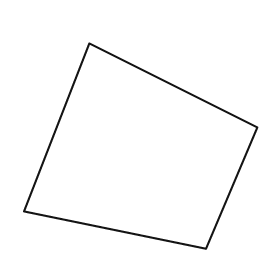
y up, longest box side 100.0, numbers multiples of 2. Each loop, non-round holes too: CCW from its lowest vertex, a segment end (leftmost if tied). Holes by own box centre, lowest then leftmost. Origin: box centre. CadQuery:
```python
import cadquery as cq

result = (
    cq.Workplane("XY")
    .moveTo(28.0, -44.0)
    .lineTo(50.0, 8.0)
    .lineTo(-22.0, 44.0)
    .lineTo(-50.0, -28.0)
    .close()
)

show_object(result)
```